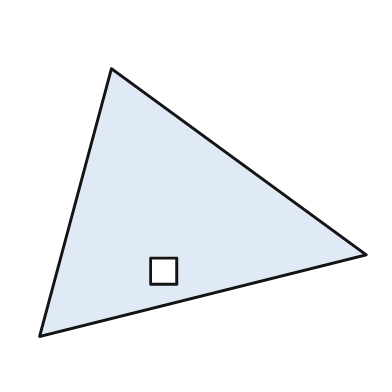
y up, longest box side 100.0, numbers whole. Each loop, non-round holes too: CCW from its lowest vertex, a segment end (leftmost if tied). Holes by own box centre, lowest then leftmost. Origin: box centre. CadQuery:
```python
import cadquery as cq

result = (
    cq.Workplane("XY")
    .moveTo(-50.0, -41.0)
    .lineTo(50.0, -16.0)
    .lineTo(-28.0, 41.0)
    .close()
    .moveTo(-16.0, -25.0)
    .lineTo(-8.0, -25.0)
    .lineTo(-8.0, -17.0)
    .lineTo(-16.0, -17.0)
    .close()
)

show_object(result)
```